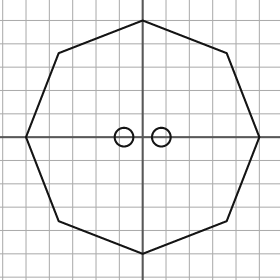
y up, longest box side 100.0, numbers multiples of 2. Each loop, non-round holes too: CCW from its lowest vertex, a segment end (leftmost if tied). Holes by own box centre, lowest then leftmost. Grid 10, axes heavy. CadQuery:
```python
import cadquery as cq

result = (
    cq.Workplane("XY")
    .moveTo(0.0, -50.0)
    .lineTo(36.0, -36.0)
    .lineTo(50.0, 0.0)
    .lineTo(36.0, 36.0)
    .lineTo(0.0, 50.0)
    .lineTo(-36.0, 36.0)
    .lineTo(-50.0, 0.0)
    .lineTo(-36.0, -36.0)
    .close()
    .moveTo(-8.0, 0.0)
    .circle(4.0)
    .moveTo(8.0, 0.0)
    .circle(4.0)
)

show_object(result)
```